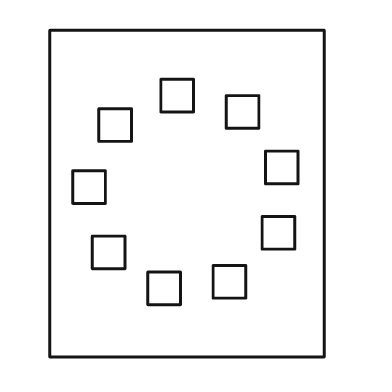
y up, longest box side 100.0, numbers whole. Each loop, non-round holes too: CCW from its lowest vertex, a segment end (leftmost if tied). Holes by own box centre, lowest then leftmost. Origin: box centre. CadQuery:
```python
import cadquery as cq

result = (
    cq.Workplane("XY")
    .moveTo(-42.0, -50.0)
    .lineTo(42.0, -50.0)
    .lineTo(42.0, 50.0)
    .lineTo(-42.0, 50.0)
    .close()
    .moveTo(-12.0, -34.0)
    .lineTo(-2.0, -34.0)
    .lineTo(-2.0, -24.0)
    .lineTo(-12.0, -24.0)
    .close()
    .moveTo(8.0, -32.0)
    .lineTo(18.0, -32.0)
    .lineTo(18.0, -22.0)
    .lineTo(8.0, -22.0)
    .close()
    .moveTo(-29.0, -23.0)
    .lineTo(-19.0, -23.0)
    .lineTo(-19.0, -13.0)
    .lineTo(-29.0, -13.0)
    .close()
    .moveTo(23.0, -17.0)
    .lineTo(33.0, -17.0)
    .lineTo(33.0, -7.0)
    .lineTo(23.0, -7.0)
    .close()
    .moveTo(-35.0, -3.0)
    .lineTo(-25.0, -3.0)
    .lineTo(-25.0, 7.0)
    .lineTo(-35.0, 7.0)
    .close()
    .moveTo(24.0, 3.0)
    .lineTo(34.0, 3.0)
    .lineTo(34.0, 13.0)
    .lineTo(24.0, 13.0)
    .close()
    .moveTo(-27.0, 16.0)
    .lineTo(-17.0, 16.0)
    .lineTo(-17.0, 26.0)
    .lineTo(-27.0, 26.0)
    .close()
    .moveTo(12.0, 20.0)
    .lineTo(22.0, 20.0)
    .lineTo(22.0, 30.0)
    .lineTo(12.0, 30.0)
    .close()
    .moveTo(-8.0, 25.0)
    .lineTo(2.0, 25.0)
    .lineTo(2.0, 35.0)
    .lineTo(-8.0, 35.0)
    .close()
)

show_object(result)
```